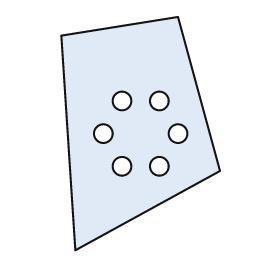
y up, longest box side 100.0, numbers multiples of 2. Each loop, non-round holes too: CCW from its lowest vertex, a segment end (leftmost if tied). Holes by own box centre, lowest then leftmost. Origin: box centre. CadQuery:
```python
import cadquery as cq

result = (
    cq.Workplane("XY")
    .moveTo(-28.0, -50.0)
    .lineTo(34.0, -16.0)
    .lineTo(16.0, 50.0)
    .lineTo(-34.0, 42.0)
    .close()
    .moveTo(-8.0, -14.0)
    .circle(4.0)
    .moveTo(8.0, -14.0)
    .circle(4.0)
    .moveTo(-16.0, 0.0)
    .circle(4.0)
    .moveTo(16.0, 0.0)
    .circle(4.0)
    .moveTo(-8.0, 14.0)
    .circle(4.0)
    .moveTo(8.0, 14.0)
    .circle(4.0)
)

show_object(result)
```